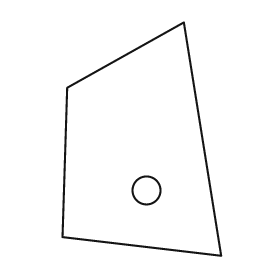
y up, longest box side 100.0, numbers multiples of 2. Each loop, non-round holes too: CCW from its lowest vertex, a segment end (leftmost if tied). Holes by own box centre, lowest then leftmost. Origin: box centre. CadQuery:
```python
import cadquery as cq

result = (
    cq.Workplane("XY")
    .moveTo(34.0, -50.0)
    .lineTo(18.0, 50.0)
    .lineTo(-32.0, 22.0)
    .lineTo(-34.0, -42.0)
    .close()
    .moveTo(2.0, -22.0)
    .circle(6.0)
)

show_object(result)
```